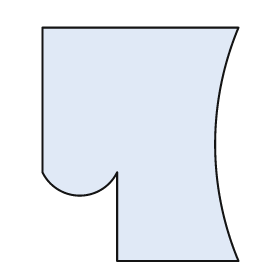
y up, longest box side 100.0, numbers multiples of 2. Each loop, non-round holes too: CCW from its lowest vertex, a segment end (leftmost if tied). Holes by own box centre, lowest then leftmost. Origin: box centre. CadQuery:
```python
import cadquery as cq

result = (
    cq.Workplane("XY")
    .moveTo(-10.0, -50.0)
    .lineTo(42.0, -50.0)
    .threePointArc((32.0, 0.0), (42.0, 50.0))
    .lineTo(-42.0, 50.0)
    .lineTo(-42.0, -12.0)
    .threePointArc((-26.0, -22.0), (-10.0, -12.0))
    .close()
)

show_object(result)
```